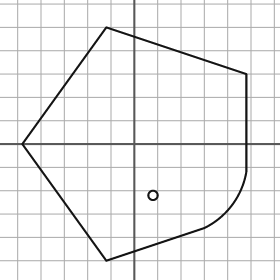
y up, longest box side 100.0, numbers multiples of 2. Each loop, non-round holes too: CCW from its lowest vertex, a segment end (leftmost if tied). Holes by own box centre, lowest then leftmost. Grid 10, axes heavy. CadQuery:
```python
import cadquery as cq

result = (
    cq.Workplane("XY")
    .moveTo(-12.0, -50.0)
    .lineTo(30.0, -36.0)
    .threePointArc((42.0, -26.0), (48.0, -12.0))
    .lineTo(48.0, 30.0)
    .lineTo(-12.0, 50.0)
    .lineTo(-48.0, 0.0)
    .close()
    .moveTo(8.0, -22.0)
    .circle(2.0)
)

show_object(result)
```